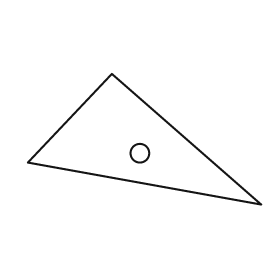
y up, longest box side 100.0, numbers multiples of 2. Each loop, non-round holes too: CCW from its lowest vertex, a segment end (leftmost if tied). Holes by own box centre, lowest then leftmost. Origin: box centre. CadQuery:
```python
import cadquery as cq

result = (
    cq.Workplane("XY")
    .moveTo(50.0, -28.0)
    .lineTo(-14.0, 28.0)
    .lineTo(-50.0, -10.0)
    .close()
    .moveTo(-2.0, -6.0)
    .circle(4.0)
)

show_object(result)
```